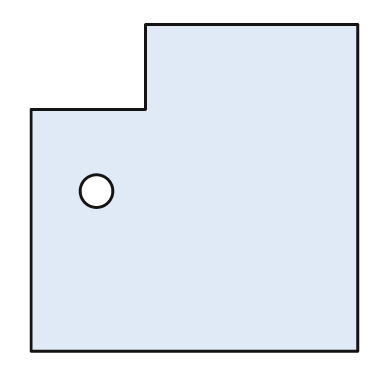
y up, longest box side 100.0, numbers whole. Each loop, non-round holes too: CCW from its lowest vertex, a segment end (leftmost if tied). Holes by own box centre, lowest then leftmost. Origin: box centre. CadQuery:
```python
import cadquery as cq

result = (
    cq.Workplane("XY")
    .moveTo(-50.0, -50.0)
    .lineTo(50.0, -50.0)
    .lineTo(50.0, 50.0)
    .lineTo(-15.0, 50.0)
    .lineTo(-15.0, 24.0)
    .lineTo(-50.0, 24.0)
    .close()
    .moveTo(-30.0, -1.0)
    .circle(5.0)
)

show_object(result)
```